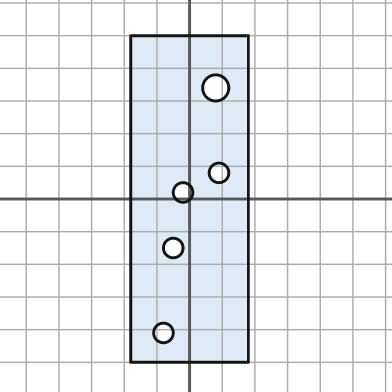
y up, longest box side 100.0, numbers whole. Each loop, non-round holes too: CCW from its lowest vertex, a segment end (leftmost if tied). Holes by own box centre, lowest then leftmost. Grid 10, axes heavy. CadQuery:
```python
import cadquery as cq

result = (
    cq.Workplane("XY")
    .moveTo(-18.0, -50.0)
    .lineTo(18.0, -50.0)
    .lineTo(18.0, 50.0)
    .lineTo(-18.0, 50.0)
    .close()
    .moveTo(-8.0, -41.0)
    .circle(3.0)
    .moveTo(-5.0, -15.0)
    .circle(3.0)
    .moveTo(-2.0, 2.0)
    .circle(3.0)
    .moveTo(9.0, 8.0)
    .circle(3.0)
    .moveTo(8.0, 34.0)
    .circle(4.0)
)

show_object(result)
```